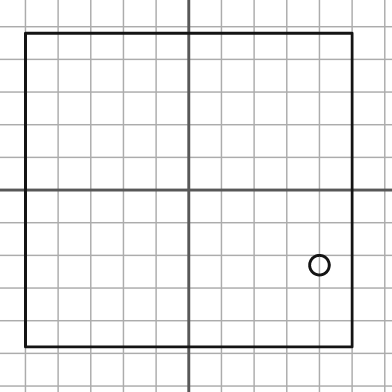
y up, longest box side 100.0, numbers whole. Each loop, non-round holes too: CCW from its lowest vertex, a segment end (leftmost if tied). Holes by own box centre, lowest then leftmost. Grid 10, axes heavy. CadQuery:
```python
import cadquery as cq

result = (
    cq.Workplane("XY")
    .moveTo(-50.0, -48.0)
    .lineTo(50.0, -48.0)
    .lineTo(50.0, 48.0)
    .lineTo(-50.0, 48.0)
    .close()
    .moveTo(40.0, -23.0)
    .circle(3.0)
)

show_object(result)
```